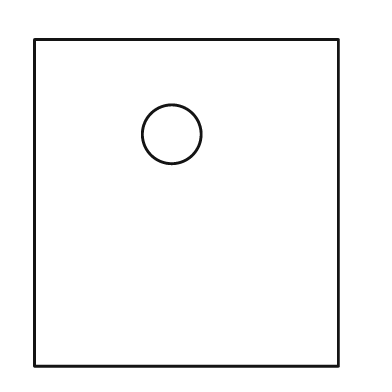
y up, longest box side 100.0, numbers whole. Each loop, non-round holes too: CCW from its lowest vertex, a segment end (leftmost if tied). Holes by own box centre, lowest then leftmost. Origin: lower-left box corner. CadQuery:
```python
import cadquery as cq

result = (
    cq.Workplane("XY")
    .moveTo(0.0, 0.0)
    .lineTo(93.0, 0.0)
    .lineTo(93.0, 100.0)
    .lineTo(0.0, 100.0)
    .close()
    .moveTo(42.0, 71.0)
    .circle(9.0)
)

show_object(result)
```